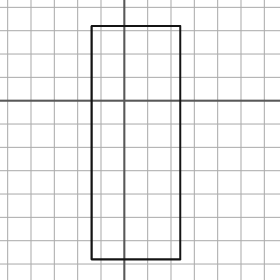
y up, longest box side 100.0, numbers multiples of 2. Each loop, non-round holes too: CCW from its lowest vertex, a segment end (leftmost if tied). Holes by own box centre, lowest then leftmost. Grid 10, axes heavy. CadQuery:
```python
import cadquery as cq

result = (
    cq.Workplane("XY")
    .moveTo(-14.0, -68.0)
    .lineTo(24.0, -68.0)
    .lineTo(24.0, 32.0)
    .lineTo(-14.0, 32.0)
    .close()
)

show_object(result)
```